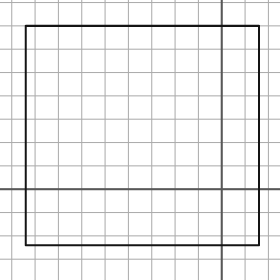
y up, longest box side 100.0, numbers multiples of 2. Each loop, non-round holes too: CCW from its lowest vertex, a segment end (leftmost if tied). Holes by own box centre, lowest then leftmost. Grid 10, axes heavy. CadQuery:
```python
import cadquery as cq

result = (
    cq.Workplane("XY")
    .moveTo(-84.0, -24.0)
    .lineTo(16.0, -24.0)
    .lineTo(16.0, 70.0)
    .lineTo(-84.0, 70.0)
    .close()
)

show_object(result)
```